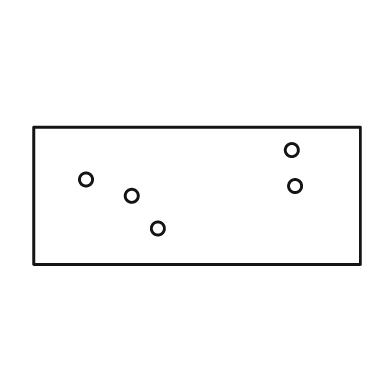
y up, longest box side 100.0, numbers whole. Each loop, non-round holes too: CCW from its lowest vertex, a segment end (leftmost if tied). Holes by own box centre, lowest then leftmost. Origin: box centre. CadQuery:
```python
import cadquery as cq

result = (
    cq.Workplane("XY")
    .moveTo(-50.0, -21.0)
    .lineTo(50.0, -21.0)
    .lineTo(50.0, 21.0)
    .lineTo(-50.0, 21.0)
    .close()
    .moveTo(-12.0, -10.0)
    .circle(2.0)
    .moveTo(-20.0, 0.0)
    .circle(2.0)
    .moveTo(30.0, 3.0)
    .circle(2.0)
    .moveTo(-34.0, 5.0)
    .circle(2.0)
    .moveTo(29.0, 14.0)
    .circle(2.0)
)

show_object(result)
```